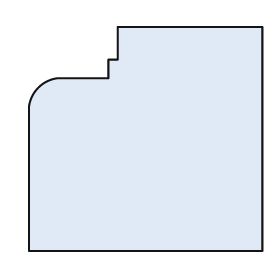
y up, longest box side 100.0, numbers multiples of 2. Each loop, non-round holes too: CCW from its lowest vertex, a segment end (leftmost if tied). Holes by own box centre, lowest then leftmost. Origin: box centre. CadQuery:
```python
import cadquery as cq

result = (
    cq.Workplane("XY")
    .moveTo(-50.0, -48.0)
    .lineTo(50.0, -48.0)
    .lineTo(50.0, 48.0)
    .lineTo(-12.0, 48.0)
    .lineTo(-12.0, 34.0)
    .lineTo(-16.0, 34.0)
    .lineTo(-16.0, 26.0)
    .lineTo(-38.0, 26.0)
    .threePointArc((-46.0, 22.0), (-50.0, 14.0))
    .close()
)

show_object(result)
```